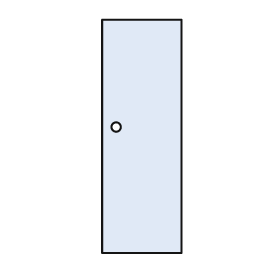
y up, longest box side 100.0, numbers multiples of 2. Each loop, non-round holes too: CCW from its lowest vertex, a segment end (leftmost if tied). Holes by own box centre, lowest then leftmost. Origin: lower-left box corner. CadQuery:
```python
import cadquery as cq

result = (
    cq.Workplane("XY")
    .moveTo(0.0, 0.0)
    .lineTo(34.0, 0.0)
    .lineTo(34.0, 100.0)
    .lineTo(0.0, 100.0)
    .close()
    .moveTo(6.0, 54.0)
    .circle(2.0)
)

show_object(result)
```